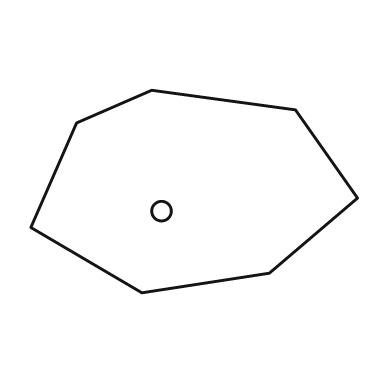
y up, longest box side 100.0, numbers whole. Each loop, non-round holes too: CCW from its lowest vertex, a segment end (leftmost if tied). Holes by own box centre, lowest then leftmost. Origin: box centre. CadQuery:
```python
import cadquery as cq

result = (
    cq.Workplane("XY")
    .moveTo(-16.0, -31.0)
    .lineTo(23.0, -25.0)
    .lineTo(50.0, -2.0)
    .lineTo(31.0, 25.0)
    .lineTo(-13.0, 31.0)
    .lineTo(-36.0, 21.0)
    .lineTo(-50.0, -11.0)
    .close()
    .moveTo(-10.0, -6.0)
    .circle(3.0)
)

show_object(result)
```